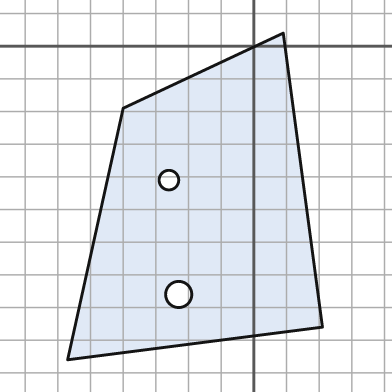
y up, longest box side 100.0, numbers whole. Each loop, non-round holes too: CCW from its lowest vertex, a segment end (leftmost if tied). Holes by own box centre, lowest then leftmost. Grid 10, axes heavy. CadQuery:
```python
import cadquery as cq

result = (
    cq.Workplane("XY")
    .moveTo(-57.0, -96.0)
    .lineTo(21.0, -86.0)
    .lineTo(9.0, 4.0)
    .lineTo(-40.0, -19.0)
    .close()
    .moveTo(-23.0, -76.0)
    .circle(4.0)
    .moveTo(-26.0, -41.0)
    .circle(3.0)
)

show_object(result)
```